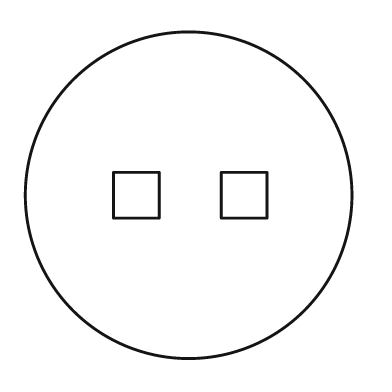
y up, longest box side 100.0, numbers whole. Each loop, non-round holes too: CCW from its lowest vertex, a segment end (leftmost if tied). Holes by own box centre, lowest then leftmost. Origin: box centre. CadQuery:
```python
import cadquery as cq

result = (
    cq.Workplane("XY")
    .moveTo(0.0, 0.0)
    .circle(50.0)
    .moveTo(-23.0, -7.0)
    .lineTo(-9.0, -7.0)
    .lineTo(-9.0, 7.0)
    .lineTo(-23.0, 7.0)
    .close()
    .moveTo(10.0, -7.0)
    .lineTo(24.0, -7.0)
    .lineTo(24.0, 7.0)
    .lineTo(10.0, 7.0)
    .close()
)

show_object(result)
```